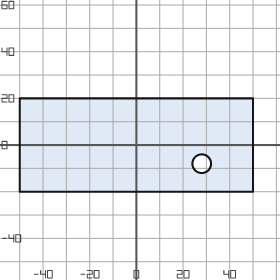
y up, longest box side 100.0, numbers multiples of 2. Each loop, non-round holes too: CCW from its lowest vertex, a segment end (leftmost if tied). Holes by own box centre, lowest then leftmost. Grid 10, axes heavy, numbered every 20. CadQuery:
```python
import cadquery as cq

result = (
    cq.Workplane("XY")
    .moveTo(-50.0, -20.0)
    .lineTo(50.0, -20.0)
    .lineTo(50.0, 20.0)
    .lineTo(-50.0, 20.0)
    .close()
    .moveTo(28.0, -8.0)
    .circle(4.0)
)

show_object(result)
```